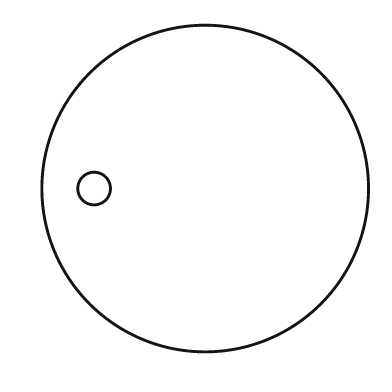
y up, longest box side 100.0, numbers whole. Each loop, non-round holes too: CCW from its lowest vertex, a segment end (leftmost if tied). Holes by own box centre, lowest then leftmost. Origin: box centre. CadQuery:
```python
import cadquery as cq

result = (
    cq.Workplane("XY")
    .moveTo(0.0, 0.0)
    .circle(50.0)
    .moveTo(-34.0, 0.0)
    .circle(5.0)
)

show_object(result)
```